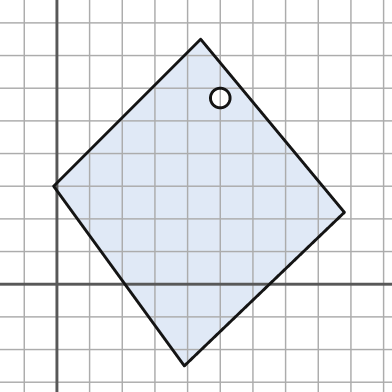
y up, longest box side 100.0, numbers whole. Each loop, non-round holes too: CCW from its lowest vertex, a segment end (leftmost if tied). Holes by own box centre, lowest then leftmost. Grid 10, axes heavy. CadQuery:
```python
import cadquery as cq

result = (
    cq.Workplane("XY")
    .moveTo(39.0, -25.0)
    .lineTo(88.0, 22.0)
    .lineTo(44.0, 75.0)
    .lineTo(-1.0, 30.0)
    .close()
    .moveTo(50.0, 57.0)
    .circle(3.0)
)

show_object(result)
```